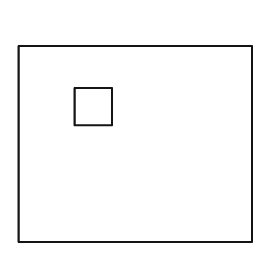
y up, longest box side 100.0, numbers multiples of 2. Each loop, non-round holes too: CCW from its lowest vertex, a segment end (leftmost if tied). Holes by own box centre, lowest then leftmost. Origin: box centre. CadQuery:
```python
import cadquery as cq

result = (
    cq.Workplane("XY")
    .moveTo(-50.0, -42.0)
    .lineTo(50.0, -42.0)
    .lineTo(50.0, 42.0)
    .lineTo(-50.0, 42.0)
    .close()
    .moveTo(-26.0, 8.0)
    .lineTo(-10.0, 8.0)
    .lineTo(-10.0, 24.0)
    .lineTo(-26.0, 24.0)
    .close()
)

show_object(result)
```